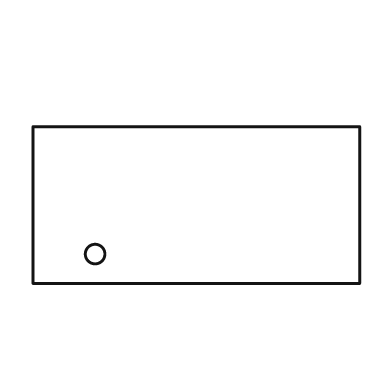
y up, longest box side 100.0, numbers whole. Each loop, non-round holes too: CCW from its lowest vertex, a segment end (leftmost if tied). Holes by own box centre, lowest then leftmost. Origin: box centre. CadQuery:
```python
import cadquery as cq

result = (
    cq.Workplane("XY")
    .moveTo(-50.0, -24.0)
    .lineTo(50.0, -24.0)
    .lineTo(50.0, 24.0)
    .lineTo(-50.0, 24.0)
    .close()
    .moveTo(-31.0, -15.0)
    .circle(3.0)
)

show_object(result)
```